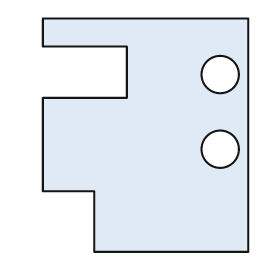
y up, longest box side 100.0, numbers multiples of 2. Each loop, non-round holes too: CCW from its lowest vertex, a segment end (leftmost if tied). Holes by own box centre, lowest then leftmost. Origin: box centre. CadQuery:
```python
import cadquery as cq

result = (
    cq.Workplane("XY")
    .moveTo(-22.0, -50.0)
    .lineTo(44.0, -50.0)
    .lineTo(44.0, 50.0)
    .lineTo(-44.0, 50.0)
    .lineTo(-44.0, 38.0)
    .lineTo(-8.0, 38.0)
    .lineTo(-8.0, 16.0)
    .lineTo(-44.0, 16.0)
    .lineTo(-44.0, -24.0)
    .lineTo(-22.0, -24.0)
    .close()
    .moveTo(32.0, -6.0)
    .circle(8.0)
    .moveTo(32.0, 26.0)
    .circle(8.0)
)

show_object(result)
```